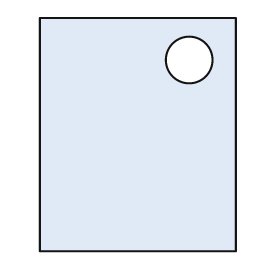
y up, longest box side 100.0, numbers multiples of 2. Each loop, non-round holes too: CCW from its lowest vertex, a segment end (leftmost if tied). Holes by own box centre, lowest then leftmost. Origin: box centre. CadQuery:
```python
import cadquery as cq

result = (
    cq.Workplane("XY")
    .moveTo(-42.0, -50.0)
    .lineTo(42.0, -50.0)
    .lineTo(42.0, 50.0)
    .lineTo(-42.0, 50.0)
    .close()
    .moveTo(22.0, 32.0)
    .circle(10.0)
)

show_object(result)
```